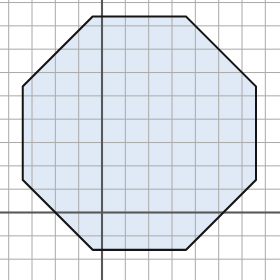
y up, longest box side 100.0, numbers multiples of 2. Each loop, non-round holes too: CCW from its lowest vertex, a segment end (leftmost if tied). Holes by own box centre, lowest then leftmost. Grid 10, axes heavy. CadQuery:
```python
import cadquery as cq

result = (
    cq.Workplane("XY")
    .moveTo(-4.0, -16.0)
    .lineTo(36.0, -16.0)
    .lineTo(66.0, 14.0)
    .lineTo(66.0, 54.0)
    .lineTo(36.0, 84.0)
    .lineTo(-4.0, 84.0)
    .lineTo(-34.0, 54.0)
    .lineTo(-34.0, 14.0)
    .close()
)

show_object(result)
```